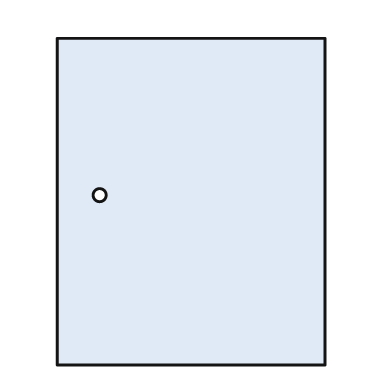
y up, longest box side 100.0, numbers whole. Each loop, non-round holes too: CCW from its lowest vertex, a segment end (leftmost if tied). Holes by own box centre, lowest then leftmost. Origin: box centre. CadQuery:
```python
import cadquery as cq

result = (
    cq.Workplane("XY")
    .moveTo(-41.0, -50.0)
    .lineTo(41.0, -50.0)
    .lineTo(41.0, 50.0)
    .lineTo(-41.0, 50.0)
    .close()
    .moveTo(-28.0, 2.0)
    .circle(2.0)
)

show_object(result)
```